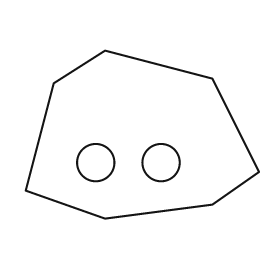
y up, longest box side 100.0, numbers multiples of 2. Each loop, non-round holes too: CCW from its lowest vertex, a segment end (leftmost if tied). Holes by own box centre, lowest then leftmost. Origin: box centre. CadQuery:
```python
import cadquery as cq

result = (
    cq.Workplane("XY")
    .moveTo(-16.0, -36.0)
    .lineTo(30.0, -30.0)
    .lineTo(50.0, -16.0)
    .lineTo(30.0, 24.0)
    .lineTo(-16.0, 36.0)
    .lineTo(-38.0, 22.0)
    .lineTo(-50.0, -24.0)
    .close()
    .moveTo(-20.0, -12.0)
    .circle(8.0)
    .moveTo(8.0, -12.0)
    .circle(8.0)
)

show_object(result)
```